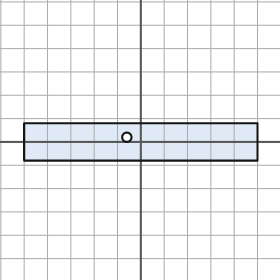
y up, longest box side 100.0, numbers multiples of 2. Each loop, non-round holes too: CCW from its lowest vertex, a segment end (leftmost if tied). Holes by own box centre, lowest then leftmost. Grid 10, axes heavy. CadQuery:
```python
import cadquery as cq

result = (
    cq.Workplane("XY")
    .moveTo(-50.0, -8.0)
    .lineTo(50.0, -8.0)
    .lineTo(50.0, 8.0)
    .lineTo(-50.0, 8.0)
    .close()
    .moveTo(-6.0, 2.0)
    .circle(2.0)
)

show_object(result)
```